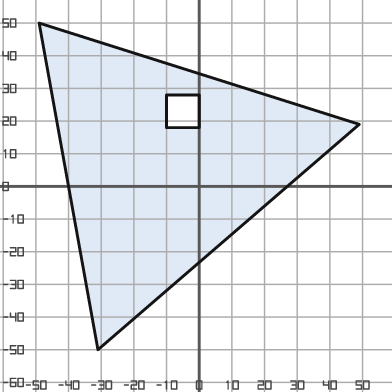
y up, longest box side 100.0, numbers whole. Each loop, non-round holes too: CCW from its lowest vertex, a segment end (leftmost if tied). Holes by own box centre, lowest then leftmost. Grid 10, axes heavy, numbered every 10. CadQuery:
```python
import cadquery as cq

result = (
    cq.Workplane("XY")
    .moveTo(-31.0, -50.0)
    .lineTo(49.0, 19.0)
    .lineTo(-49.0, 50.0)
    .close()
    .moveTo(-10.0, 18.0)
    .lineTo(0.0, 18.0)
    .lineTo(0.0, 28.0)
    .lineTo(-10.0, 28.0)
    .close()
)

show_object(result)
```